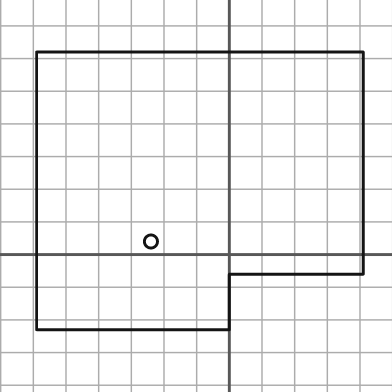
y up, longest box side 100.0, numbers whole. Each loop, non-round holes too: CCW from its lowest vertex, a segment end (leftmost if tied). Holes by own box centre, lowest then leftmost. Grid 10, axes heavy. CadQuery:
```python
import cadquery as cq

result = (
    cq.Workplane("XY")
    .moveTo(-59.0, -23.0)
    .lineTo(0.0, -23.0)
    .lineTo(0.0, -6.0)
    .lineTo(41.0, -6.0)
    .lineTo(41.0, 62.0)
    .lineTo(-59.0, 62.0)
    .close()
    .moveTo(-24.0, 4.0)
    .circle(2.0)
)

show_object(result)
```